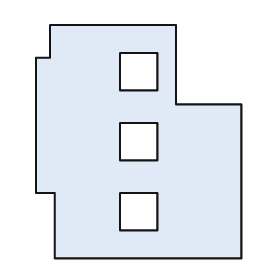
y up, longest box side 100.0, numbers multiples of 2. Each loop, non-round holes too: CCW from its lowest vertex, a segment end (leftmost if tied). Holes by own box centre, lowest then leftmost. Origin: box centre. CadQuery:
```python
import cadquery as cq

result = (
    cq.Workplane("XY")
    .moveTo(-36.0, -50.0)
    .lineTo(44.0, -50.0)
    .lineTo(44.0, 16.0)
    .lineTo(16.0, 16.0)
    .lineTo(16.0, 50.0)
    .lineTo(-38.0, 50.0)
    .lineTo(-38.0, 36.0)
    .lineTo(-44.0, 36.0)
    .lineTo(-44.0, -22.0)
    .lineTo(-36.0, -22.0)
    .close()
    .moveTo(-8.0, -38.0)
    .lineTo(8.0, -38.0)
    .lineTo(8.0, -22.0)
    .lineTo(-8.0, -22.0)
    .close()
    .moveTo(-8.0, -8.0)
    .lineTo(8.0, -8.0)
    .lineTo(8.0, 8.0)
    .lineTo(-8.0, 8.0)
    .close()
    .moveTo(-8.0, 22.0)
    .lineTo(8.0, 22.0)
    .lineTo(8.0, 38.0)
    .lineTo(-8.0, 38.0)
    .close()
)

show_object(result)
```